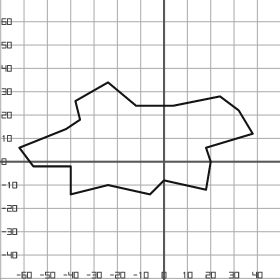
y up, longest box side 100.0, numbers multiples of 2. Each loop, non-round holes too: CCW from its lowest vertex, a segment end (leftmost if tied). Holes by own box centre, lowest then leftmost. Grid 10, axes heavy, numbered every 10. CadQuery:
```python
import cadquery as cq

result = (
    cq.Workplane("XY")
    .moveTo(-40.0, -14.0)
    .lineTo(-24.0, -10.0)
    .lineTo(-6.0, -14.0)
    .lineTo(0.0, -8.0)
    .lineTo(18.0, -12.0)
    .lineTo(20.0, 0.0)
    .lineTo(18.0, 6.0)
    .lineTo(38.0, 12.0)
    .lineTo(32.0, 22.0)
    .lineTo(24.0, 28.0)
    .lineTo(4.0, 24.0)
    .lineTo(-12.0, 24.0)
    .lineTo(-24.0, 34.0)
    .lineTo(-38.0, 26.0)
    .lineTo(-36.0, 18.0)
    .lineTo(-42.0, 14.0)
    .lineTo(-62.0, 6.0)
    .lineTo(-56.0, -2.0)
    .lineTo(-40.0, -2.0)
    .close()
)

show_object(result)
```